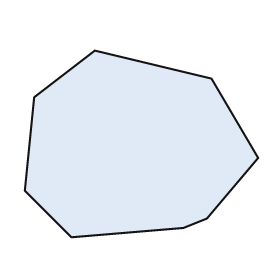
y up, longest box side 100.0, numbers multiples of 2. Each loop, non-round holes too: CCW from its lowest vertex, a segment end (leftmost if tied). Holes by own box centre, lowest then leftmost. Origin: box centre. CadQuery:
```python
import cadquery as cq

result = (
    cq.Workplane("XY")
    .moveTo(-30.0, -40.0)
    .lineTo(18.0, -36.0)
    .lineTo(28.0, -32.0)
    .lineTo(50.0, -6.0)
    .lineTo(30.0, 28.0)
    .lineTo(-20.0, 40.0)
    .lineTo(-46.0, 20.0)
    .lineTo(-50.0, -20.0)
    .close()
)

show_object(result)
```